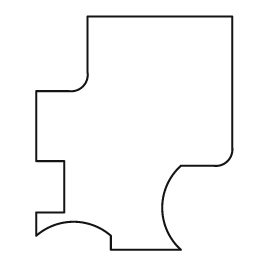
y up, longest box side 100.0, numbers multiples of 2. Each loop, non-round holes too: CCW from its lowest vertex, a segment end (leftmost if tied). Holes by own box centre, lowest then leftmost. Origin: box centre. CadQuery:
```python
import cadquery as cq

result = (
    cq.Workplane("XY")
    .moveTo(-10.0, -50.0)
    .lineTo(20.0, -50.0)
    .threePointArc((12.0, -32.0), (20.0, -14.0))
    .lineTo(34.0, -14.0)
    .threePointArc((40.0, -12.0), (42.0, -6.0))
    .lineTo(42.0, 50.0)
    .lineTo(-20.0, 50.0)
    .lineTo(-20.0, 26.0)
    .threePointArc((-22.0, 20.0), (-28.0, 18.0))
    .lineTo(-42.0, 18.0)
    .lineTo(-42.0, -12.0)
    .lineTo(-30.0, -12.0)
    .lineTo(-30.0, -34.0)
    .lineTo(-42.0, -34.0)
    .lineTo(-42.0, -44.0)
    .threePointArc((-26.0, -38.0), (-10.0, -44.0))
    .close()
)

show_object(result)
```